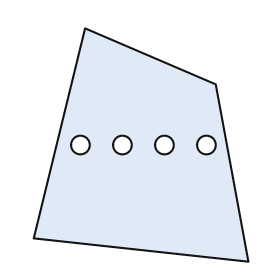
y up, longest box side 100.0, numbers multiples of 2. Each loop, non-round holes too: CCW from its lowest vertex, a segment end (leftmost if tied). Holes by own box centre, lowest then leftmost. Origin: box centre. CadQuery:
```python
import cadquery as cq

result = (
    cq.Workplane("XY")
    .moveTo(46.0, -50.0)
    .lineTo(32.0, 26.0)
    .lineTo(-24.0, 50.0)
    .lineTo(-46.0, -40.0)
    .close()
    .moveTo(-26.0, 0.0)
    .circle(4.0)
    .moveTo(-8.0, 0.0)
    .circle(4.0)
    .moveTo(10.0, 0.0)
    .circle(4.0)
    .moveTo(28.0, 0.0)
    .circle(4.0)
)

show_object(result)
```